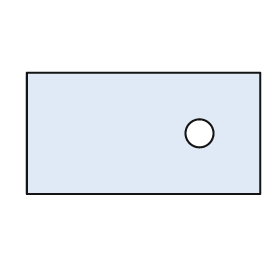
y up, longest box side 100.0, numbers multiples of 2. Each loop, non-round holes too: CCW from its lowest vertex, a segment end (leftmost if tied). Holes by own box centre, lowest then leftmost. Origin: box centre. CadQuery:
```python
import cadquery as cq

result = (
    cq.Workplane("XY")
    .moveTo(-50.0, -26.0)
    .lineTo(50.0, -26.0)
    .lineTo(50.0, 26.0)
    .lineTo(-50.0, 26.0)
    .close()
    .moveTo(24.0, 0.0)
    .circle(6.0)
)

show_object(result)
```